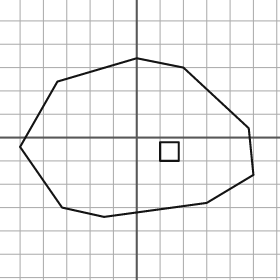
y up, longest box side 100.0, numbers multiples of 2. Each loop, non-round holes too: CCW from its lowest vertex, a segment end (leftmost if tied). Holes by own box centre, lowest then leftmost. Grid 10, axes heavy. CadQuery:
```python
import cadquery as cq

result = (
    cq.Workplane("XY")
    .moveTo(-14.0, -34.0)
    .lineTo(30.0, -28.0)
    .lineTo(50.0, -16.0)
    .lineTo(48.0, 4.0)
    .lineTo(20.0, 30.0)
    .lineTo(0.0, 34.0)
    .lineTo(-34.0, 24.0)
    .lineTo(-50.0, -4.0)
    .lineTo(-32.0, -30.0)
    .close()
    .moveTo(10.0, -10.0)
    .lineTo(18.0, -10.0)
    .lineTo(18.0, -2.0)
    .lineTo(10.0, -2.0)
    .close()
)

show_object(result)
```